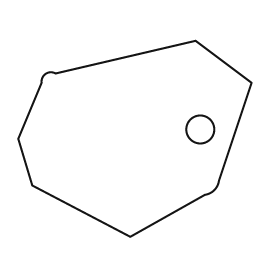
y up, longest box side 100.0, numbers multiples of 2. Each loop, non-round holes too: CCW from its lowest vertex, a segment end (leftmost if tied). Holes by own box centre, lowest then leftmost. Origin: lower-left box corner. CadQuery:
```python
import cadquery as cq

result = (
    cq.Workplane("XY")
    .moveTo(48.0, 0.0)
    .lineTo(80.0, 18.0)
    .threePointArc((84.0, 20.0), (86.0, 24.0))
    .lineTo(100.0, 66.0)
    .lineTo(76.0, 84.0)
    .lineTo(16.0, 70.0)
    .threePointArc((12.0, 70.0), (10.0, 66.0))
    .lineTo(0.0, 42.0)
    .lineTo(6.0, 22.0)
    .close()
    .moveTo(78.0, 46.0)
    .circle(6.0)
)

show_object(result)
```